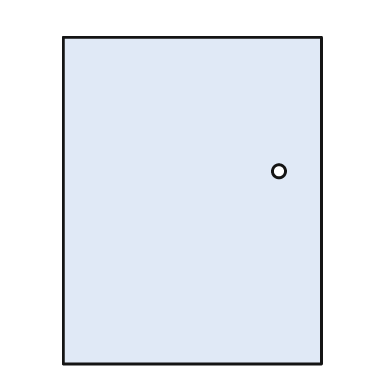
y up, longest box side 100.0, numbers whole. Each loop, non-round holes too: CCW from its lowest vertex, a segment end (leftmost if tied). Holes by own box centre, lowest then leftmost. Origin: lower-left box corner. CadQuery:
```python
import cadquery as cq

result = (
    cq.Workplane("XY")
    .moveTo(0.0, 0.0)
    .lineTo(79.0, 0.0)
    .lineTo(79.0, 100.0)
    .lineTo(0.0, 100.0)
    .close()
    .moveTo(66.0, 59.0)
    .circle(2.0)
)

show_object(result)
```